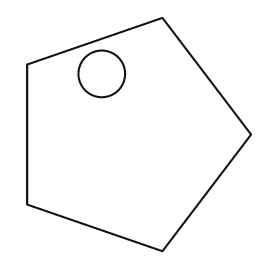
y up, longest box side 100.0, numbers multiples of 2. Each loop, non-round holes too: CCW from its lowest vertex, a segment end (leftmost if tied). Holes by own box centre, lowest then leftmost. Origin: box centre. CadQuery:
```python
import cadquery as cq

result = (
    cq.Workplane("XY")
    .moveTo(10.0, -50.0)
    .lineTo(48.0, 0.0)
    .lineTo(10.0, 50.0)
    .lineTo(-48.0, 30.0)
    .lineTo(-48.0, -30.0)
    .close()
    .moveTo(-16.0, 26.0)
    .circle(10.0)
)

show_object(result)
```